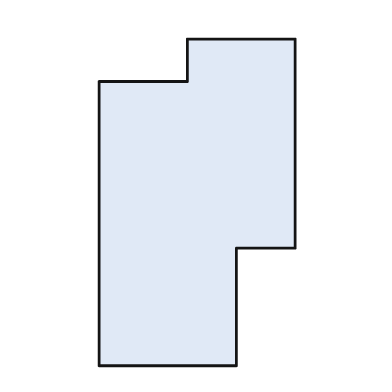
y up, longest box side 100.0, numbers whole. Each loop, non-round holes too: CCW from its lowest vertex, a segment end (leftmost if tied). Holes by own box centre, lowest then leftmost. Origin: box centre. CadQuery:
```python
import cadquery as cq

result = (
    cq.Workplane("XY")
    .moveTo(-30.0, -50.0)
    .lineTo(12.0, -50.0)
    .lineTo(12.0, -14.0)
    .lineTo(30.0, -14.0)
    .lineTo(30.0, 50.0)
    .lineTo(-3.0, 50.0)
    .lineTo(-3.0, 37.0)
    .lineTo(-30.0, 37.0)
    .close()
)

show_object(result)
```